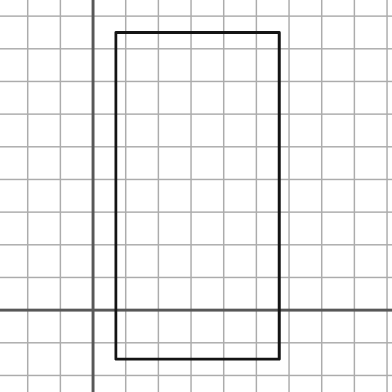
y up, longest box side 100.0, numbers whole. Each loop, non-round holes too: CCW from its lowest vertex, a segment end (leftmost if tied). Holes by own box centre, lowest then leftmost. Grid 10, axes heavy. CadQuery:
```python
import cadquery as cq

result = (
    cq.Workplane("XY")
    .moveTo(7.0, -15.0)
    .lineTo(57.0, -15.0)
    .lineTo(57.0, 85.0)
    .lineTo(7.0, 85.0)
    .close()
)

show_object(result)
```